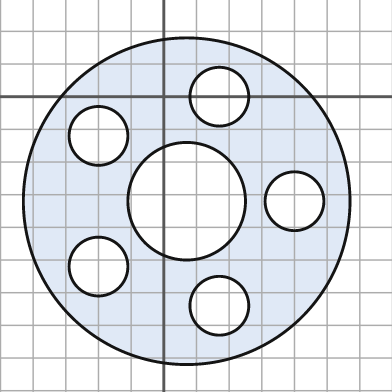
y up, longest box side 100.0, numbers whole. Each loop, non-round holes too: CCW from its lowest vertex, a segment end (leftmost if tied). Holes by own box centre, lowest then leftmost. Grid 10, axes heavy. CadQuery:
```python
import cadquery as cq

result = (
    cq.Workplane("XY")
    .moveTo(7.0, -32.0)
    .circle(50.0)
    .moveTo(17.0, -64.0)
    .circle(9.0)
    .moveTo(-20.0, -52.0)
    .circle(9.0)
    .moveTo(7.0, -32.0)
    .circle(18.0)
    .moveTo(40.0, -32.0)
    .circle(9.0)
    .moveTo(-20.0, -12.0)
    .circle(9.0)
    .moveTo(17.0, 0.0)
    .circle(9.0)
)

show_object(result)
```